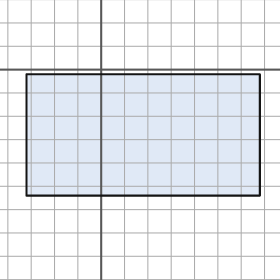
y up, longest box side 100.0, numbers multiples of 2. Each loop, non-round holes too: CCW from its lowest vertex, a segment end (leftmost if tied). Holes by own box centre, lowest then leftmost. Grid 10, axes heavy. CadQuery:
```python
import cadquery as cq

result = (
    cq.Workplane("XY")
    .moveTo(-32.0, -54.0)
    .lineTo(68.0, -54.0)
    .lineTo(68.0, -2.0)
    .lineTo(-32.0, -2.0)
    .close()
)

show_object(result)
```